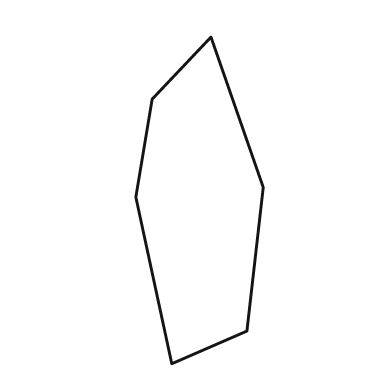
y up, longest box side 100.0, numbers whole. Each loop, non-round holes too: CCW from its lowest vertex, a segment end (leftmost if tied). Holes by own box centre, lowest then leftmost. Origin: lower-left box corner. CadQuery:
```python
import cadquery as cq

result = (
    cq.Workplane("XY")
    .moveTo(11.0, 0.0)
    .lineTo(34.0, 10.0)
    .lineTo(39.0, 54.0)
    .lineTo(23.0, 100.0)
    .lineTo(5.0, 81.0)
    .lineTo(0.0, 51.0)
    .close()
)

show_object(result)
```